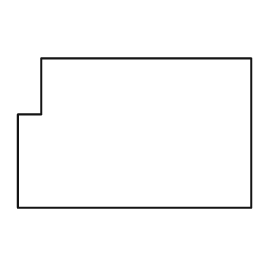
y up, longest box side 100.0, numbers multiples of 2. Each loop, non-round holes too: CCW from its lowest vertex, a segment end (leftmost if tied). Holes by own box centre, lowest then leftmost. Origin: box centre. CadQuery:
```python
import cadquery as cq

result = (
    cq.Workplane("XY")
    .moveTo(-50.0, -32.0)
    .lineTo(50.0, -32.0)
    .lineTo(50.0, 32.0)
    .lineTo(-40.0, 32.0)
    .lineTo(-40.0, 8.0)
    .lineTo(-50.0, 8.0)
    .close()
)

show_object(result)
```